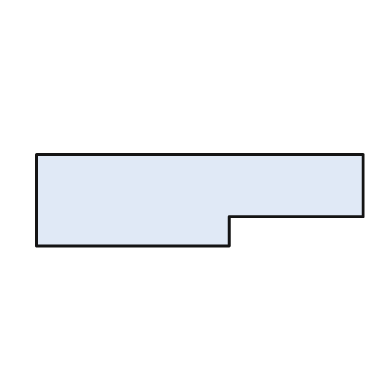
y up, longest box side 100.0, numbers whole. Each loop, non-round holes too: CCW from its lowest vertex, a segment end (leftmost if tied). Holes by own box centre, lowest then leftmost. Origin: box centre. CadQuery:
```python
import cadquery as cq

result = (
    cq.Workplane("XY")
    .moveTo(-50.0, -14.0)
    .lineTo(9.0, -14.0)
    .lineTo(9.0, -5.0)
    .lineTo(50.0, -5.0)
    .lineTo(50.0, 14.0)
    .lineTo(-50.0, 14.0)
    .close()
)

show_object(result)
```